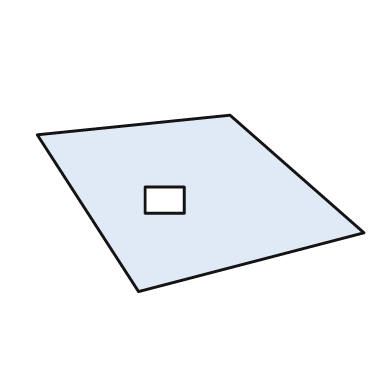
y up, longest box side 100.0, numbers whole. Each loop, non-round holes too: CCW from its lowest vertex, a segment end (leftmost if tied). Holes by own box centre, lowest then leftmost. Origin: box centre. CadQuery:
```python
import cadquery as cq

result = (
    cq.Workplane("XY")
    .moveTo(-19.0, -27.0)
    .lineTo(50.0, -9.0)
    .lineTo(9.0, 27.0)
    .lineTo(-50.0, 21.0)
    .close()
    .moveTo(-17.0, -3.0)
    .lineTo(-5.0, -3.0)
    .lineTo(-5.0, 5.0)
    .lineTo(-17.0, 5.0)
    .close()
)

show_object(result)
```